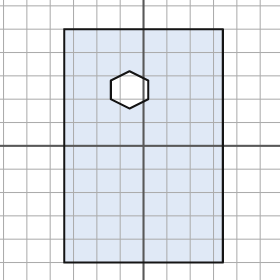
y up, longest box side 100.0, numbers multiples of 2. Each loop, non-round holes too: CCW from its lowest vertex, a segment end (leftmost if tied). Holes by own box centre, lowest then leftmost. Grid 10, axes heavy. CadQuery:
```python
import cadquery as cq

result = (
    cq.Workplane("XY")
    .moveTo(-34.0, -50.0)
    .lineTo(34.0, -50.0)
    .lineTo(34.0, 50.0)
    .lineTo(-34.0, 50.0)
    .close()
    .moveTo(-6.0, 16.0)
    .lineTo(2.0, 20.0)
    .lineTo(2.0, 28.0)
    .lineTo(-6.0, 32.0)
    .lineTo(-14.0, 28.0)
    .lineTo(-14.0, 20.0)
    .close()
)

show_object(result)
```